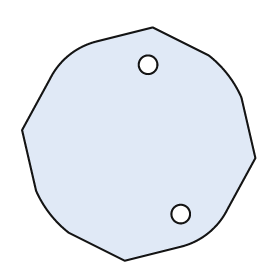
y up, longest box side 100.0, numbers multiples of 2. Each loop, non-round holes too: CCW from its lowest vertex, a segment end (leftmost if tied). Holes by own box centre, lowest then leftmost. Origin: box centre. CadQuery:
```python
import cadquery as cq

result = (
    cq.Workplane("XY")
    .moveTo(-6.0, -50.0)
    .lineTo(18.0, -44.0)
    .threePointArc((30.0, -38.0), (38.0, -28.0))
    .lineTo(50.0, -6.0)
    .lineTo(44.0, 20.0)
    .threePointArc((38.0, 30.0), (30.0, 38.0))
    .lineTo(6.0, 50.0)
    .lineTo(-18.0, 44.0)
    .threePointArc((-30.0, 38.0), (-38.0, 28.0))
    .lineTo(-50.0, 6.0)
    .lineTo(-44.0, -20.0)
    .threePointArc((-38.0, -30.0), (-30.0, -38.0))
    .close()
    .moveTo(18.0, -30.0)
    .circle(4.0)
    .moveTo(4.0, 34.0)
    .circle(4.0)
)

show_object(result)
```